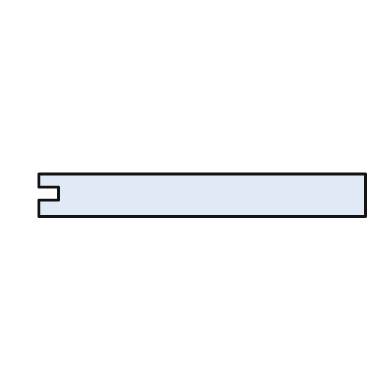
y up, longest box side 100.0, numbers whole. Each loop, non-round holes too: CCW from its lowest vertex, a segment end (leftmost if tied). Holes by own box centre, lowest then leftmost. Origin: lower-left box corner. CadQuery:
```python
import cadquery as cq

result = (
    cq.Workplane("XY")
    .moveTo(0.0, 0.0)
    .lineTo(100.0, 0.0)
    .lineTo(100.0, 13.0)
    .lineTo(0.0, 13.0)
    .lineTo(0.0, 9.0)
    .lineTo(6.0, 9.0)
    .lineTo(6.0, 5.0)
    .lineTo(0.0, 5.0)
    .close()
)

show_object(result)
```